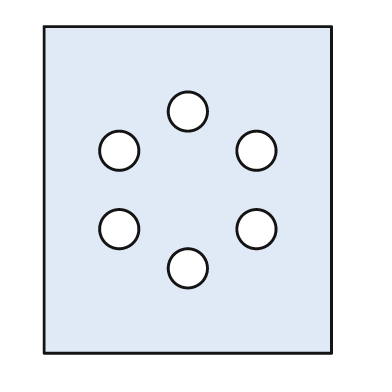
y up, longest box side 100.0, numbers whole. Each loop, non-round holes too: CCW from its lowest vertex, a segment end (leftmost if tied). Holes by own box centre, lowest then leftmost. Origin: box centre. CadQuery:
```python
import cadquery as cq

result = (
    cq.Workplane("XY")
    .moveTo(-44.0, -50.0)
    .lineTo(44.0, -50.0)
    .lineTo(44.0, 50.0)
    .lineTo(-44.0, 50.0)
    .close()
    .moveTo(0.0, -24.0)
    .circle(6.0)
    .moveTo(-21.0, -12.0)
    .circle(6.0)
    .moveTo(21.0, -12.0)
    .circle(6.0)
    .moveTo(-21.0, 12.0)
    .circle(6.0)
    .moveTo(21.0, 12.0)
    .circle(6.0)
    .moveTo(0.0, 24.0)
    .circle(6.0)
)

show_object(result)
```